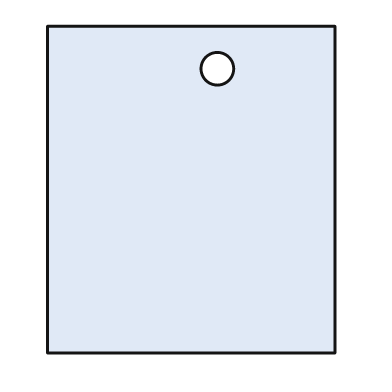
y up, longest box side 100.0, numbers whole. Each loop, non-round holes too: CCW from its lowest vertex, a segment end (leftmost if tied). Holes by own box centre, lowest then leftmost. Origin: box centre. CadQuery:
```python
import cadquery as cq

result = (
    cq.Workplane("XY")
    .moveTo(-44.0, -50.0)
    .lineTo(44.0, -50.0)
    .lineTo(44.0, 50.0)
    .lineTo(-44.0, 50.0)
    .close()
    .moveTo(8.0, 37.0)
    .circle(5.0)
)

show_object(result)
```